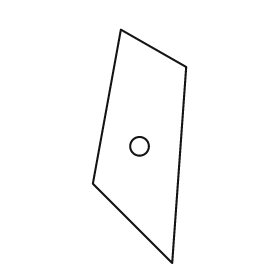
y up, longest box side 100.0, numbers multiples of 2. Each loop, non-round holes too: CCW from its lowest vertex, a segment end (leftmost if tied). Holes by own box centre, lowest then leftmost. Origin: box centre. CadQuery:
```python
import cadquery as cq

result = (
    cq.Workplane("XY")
    .moveTo(14.0, -50.0)
    .lineTo(20.0, 34.0)
    .lineTo(-8.0, 50.0)
    .lineTo(-20.0, -16.0)
    .close()
    .moveTo(0.0, 0.0)
    .circle(4.0)
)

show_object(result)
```